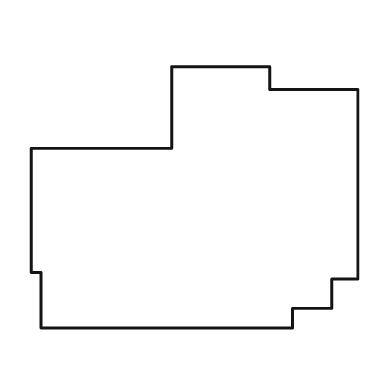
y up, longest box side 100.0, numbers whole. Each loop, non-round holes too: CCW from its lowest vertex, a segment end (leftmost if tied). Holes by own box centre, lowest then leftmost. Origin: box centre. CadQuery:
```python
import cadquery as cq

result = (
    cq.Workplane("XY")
    .moveTo(-47.0, -40.0)
    .lineTo(30.0, -40.0)
    .lineTo(30.0, -34.0)
    .lineTo(42.0, -34.0)
    .lineTo(42.0, -25.0)
    .lineTo(50.0, -25.0)
    .lineTo(50.0, 33.0)
    .lineTo(23.0, 33.0)
    .lineTo(23.0, 40.0)
    .lineTo(-7.0, 40.0)
    .lineTo(-7.0, 15.0)
    .lineTo(-50.0, 15.0)
    .lineTo(-50.0, -23.0)
    .lineTo(-47.0, -23.0)
    .close()
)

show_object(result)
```